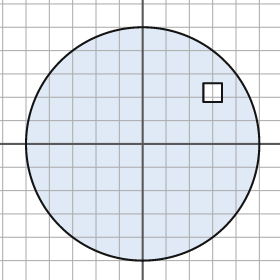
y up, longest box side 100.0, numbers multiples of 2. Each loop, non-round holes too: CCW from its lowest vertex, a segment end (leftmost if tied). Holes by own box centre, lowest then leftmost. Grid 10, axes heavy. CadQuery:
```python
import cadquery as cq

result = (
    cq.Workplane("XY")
    .moveTo(0.0, 0.0)
    .circle(50.0)
    .moveTo(26.0, 18.0)
    .lineTo(34.0, 18.0)
    .lineTo(34.0, 26.0)
    .lineTo(26.0, 26.0)
    .close()
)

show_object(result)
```